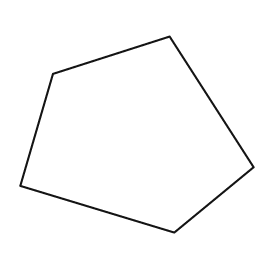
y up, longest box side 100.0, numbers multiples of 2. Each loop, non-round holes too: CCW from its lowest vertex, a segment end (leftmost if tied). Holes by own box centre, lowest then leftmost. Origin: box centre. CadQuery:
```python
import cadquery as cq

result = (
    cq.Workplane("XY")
    .moveTo(16.0, -42.0)
    .lineTo(50.0, -14.0)
    .lineTo(14.0, 42.0)
    .lineTo(-36.0, 26.0)
    .lineTo(-50.0, -22.0)
    .close()
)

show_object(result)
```